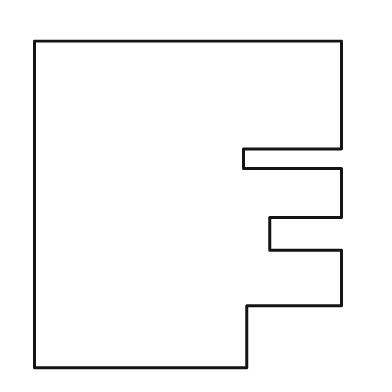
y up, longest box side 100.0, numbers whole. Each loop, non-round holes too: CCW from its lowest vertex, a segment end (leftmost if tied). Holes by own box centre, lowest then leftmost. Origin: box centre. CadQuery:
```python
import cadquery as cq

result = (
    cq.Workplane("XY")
    .moveTo(-47.0, -50.0)
    .lineTo(18.0, -50.0)
    .lineTo(18.0, -31.0)
    .lineTo(47.0, -31.0)
    .lineTo(47.0, -14.0)
    .lineTo(25.0, -14.0)
    .lineTo(25.0, -4.0)
    .lineTo(47.0, -4.0)
    .lineTo(47.0, 11.0)
    .lineTo(17.0, 11.0)
    .lineTo(17.0, 17.0)
    .lineTo(47.0, 17.0)
    .lineTo(47.0, 50.0)
    .lineTo(-47.0, 50.0)
    .close()
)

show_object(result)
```